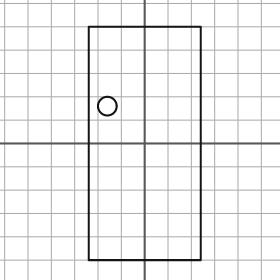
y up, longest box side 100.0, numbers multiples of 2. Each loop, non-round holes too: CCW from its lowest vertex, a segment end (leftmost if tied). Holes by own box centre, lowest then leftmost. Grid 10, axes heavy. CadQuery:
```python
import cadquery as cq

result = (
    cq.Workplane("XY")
    .moveTo(-24.0, -50.0)
    .lineTo(24.0, -50.0)
    .lineTo(24.0, 50.0)
    .lineTo(-24.0, 50.0)
    .close()
    .moveTo(-16.0, 16.0)
    .circle(4.0)
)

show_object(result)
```